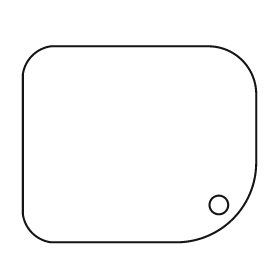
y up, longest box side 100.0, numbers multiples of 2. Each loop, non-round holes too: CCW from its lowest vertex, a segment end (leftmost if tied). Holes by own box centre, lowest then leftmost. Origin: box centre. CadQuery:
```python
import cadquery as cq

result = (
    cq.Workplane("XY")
    .moveTo(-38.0, -42.0)
    .lineTo(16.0, -42.0)
    .threePointArc((40.0, -32.0), (50.0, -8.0))
    .lineTo(50.0, 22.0)
    .threePointArc((44.0, 36.0), (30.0, 42.0))
    .lineTo(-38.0, 42.0)
    .threePointArc((-46.0, 38.0), (-50.0, 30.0))
    .lineTo(-50.0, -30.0)
    .threePointArc((-46.0, -38.0), (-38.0, -42.0))
    .close()
    .moveTo(34.0, -26.0)
    .circle(4.0)
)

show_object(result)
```